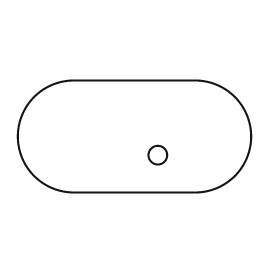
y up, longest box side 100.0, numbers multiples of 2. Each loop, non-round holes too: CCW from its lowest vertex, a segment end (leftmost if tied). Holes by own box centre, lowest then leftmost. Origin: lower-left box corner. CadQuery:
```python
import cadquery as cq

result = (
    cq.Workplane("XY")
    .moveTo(24.0, 0.0)
    .lineTo(76.0, 0.0)
    .threePointArc((100.0, 24.0), (76.0, 48.0))
    .lineTo(24.0, 48.0)
    .threePointArc((0.0, 24.0), (24.0, 0.0))
    .close()
    .moveTo(60.0, 16.0)
    .circle(4.0)
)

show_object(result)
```